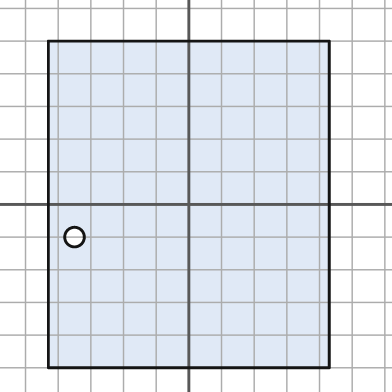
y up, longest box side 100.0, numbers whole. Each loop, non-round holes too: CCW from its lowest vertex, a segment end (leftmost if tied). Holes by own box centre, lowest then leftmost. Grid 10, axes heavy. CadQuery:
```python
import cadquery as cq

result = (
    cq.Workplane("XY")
    .moveTo(-43.0, -50.0)
    .lineTo(43.0, -50.0)
    .lineTo(43.0, 50.0)
    .lineTo(-43.0, 50.0)
    .close()
    .moveTo(-35.0, -10.0)
    .circle(3.0)
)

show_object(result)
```